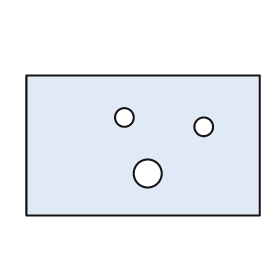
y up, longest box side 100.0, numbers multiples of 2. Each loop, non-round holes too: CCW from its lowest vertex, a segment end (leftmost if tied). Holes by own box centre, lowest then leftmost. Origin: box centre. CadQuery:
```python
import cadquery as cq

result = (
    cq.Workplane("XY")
    .moveTo(-50.0, -30.0)
    .lineTo(50.0, -30.0)
    .lineTo(50.0, 30.0)
    .lineTo(-50.0, 30.0)
    .close()
    .moveTo(2.0, -12.0)
    .circle(6.0)
    .moveTo(26.0, 8.0)
    .circle(4.0)
    .moveTo(-8.0, 12.0)
    .circle(4.0)
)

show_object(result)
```